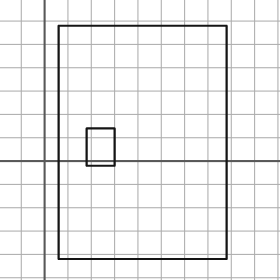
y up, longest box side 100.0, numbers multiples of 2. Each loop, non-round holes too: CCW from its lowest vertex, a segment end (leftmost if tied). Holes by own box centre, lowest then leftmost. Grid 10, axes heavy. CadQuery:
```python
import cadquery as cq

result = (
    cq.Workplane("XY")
    .moveTo(6.0, -42.0)
    .lineTo(78.0, -42.0)
    .lineTo(78.0, 58.0)
    .lineTo(6.0, 58.0)
    .close()
    .moveTo(18.0, -2.0)
    .lineTo(30.0, -2.0)
    .lineTo(30.0, 14.0)
    .lineTo(18.0, 14.0)
    .close()
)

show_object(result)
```